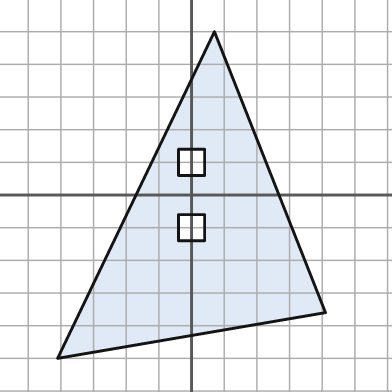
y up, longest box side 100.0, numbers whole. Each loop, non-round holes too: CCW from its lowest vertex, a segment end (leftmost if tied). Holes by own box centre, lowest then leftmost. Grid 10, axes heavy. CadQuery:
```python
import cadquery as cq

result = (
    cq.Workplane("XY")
    .moveTo(-41.0, -50.0)
    .lineTo(41.0, -36.0)
    .lineTo(7.0, 50.0)
    .close()
    .moveTo(-4.0, -14.0)
    .lineTo(4.0, -14.0)
    .lineTo(4.0, -6.0)
    .lineTo(-4.0, -6.0)
    .close()
    .moveTo(-4.0, 6.0)
    .lineTo(4.0, 6.0)
    .lineTo(4.0, 14.0)
    .lineTo(-4.0, 14.0)
    .close()
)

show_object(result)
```